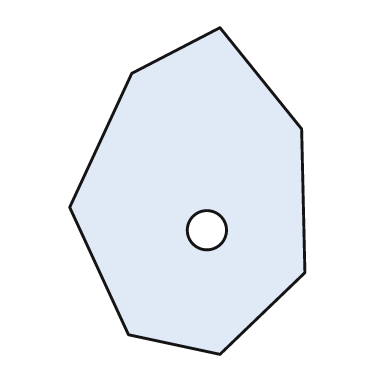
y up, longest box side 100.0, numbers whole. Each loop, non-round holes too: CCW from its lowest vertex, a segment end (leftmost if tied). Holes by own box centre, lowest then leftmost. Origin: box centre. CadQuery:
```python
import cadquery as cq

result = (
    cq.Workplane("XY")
    .moveTo(10.0, -50.0)
    .lineTo(36.0, -25.0)
    .lineTo(35.0, 19.0)
    .lineTo(10.0, 50.0)
    .lineTo(-17.0, 36.0)
    .lineTo(-36.0, -5.0)
    .lineTo(-18.0, -44.0)
    .close()
    .moveTo(6.0, -12.0)
    .circle(6.0)
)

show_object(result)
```